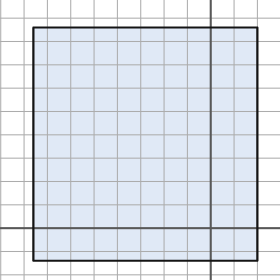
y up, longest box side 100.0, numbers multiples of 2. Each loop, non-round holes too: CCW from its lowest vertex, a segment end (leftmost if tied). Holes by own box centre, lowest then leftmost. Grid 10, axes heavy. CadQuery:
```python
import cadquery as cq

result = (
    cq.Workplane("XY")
    .moveTo(-76.0, -14.0)
    .lineTo(20.0, -14.0)
    .lineTo(20.0, 86.0)
    .lineTo(-76.0, 86.0)
    .close()
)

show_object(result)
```